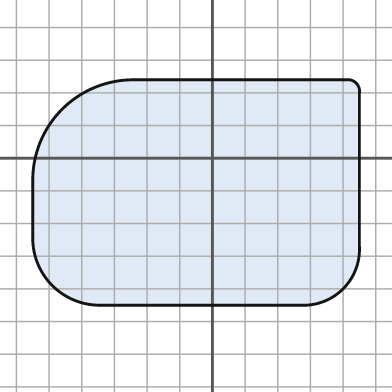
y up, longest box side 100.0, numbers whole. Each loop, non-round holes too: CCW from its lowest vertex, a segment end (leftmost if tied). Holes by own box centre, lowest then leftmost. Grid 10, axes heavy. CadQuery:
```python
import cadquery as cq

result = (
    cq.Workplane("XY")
    .moveTo(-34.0, -45.0)
    .lineTo(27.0, -45.0)
    .threePointArc((40.0, -40.0), (45.0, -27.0))
    .lineTo(45.0, 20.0)
    .threePointArc((44.0, 23.0), (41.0, 24.0))
    .lineTo(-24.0, 24.0)
    .threePointArc((-46.0, 15.0), (-55.0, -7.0))
    .lineTo(-55.0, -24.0)
    .threePointArc((-49.0, -39.0), (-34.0, -45.0))
    .close()
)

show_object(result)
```